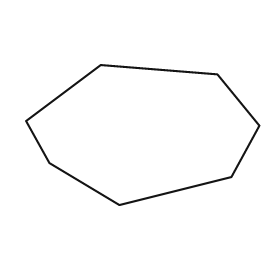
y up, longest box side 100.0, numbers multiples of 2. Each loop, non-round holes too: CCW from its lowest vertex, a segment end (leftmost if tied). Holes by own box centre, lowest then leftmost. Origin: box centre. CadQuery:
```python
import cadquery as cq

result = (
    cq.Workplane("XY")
    .moveTo(-10.0, -30.0)
    .lineTo(38.0, -18.0)
    .lineTo(50.0, 4.0)
    .lineTo(32.0, 26.0)
    .lineTo(-18.0, 30.0)
    .lineTo(-50.0, 6.0)
    .lineTo(-40.0, -12.0)
    .close()
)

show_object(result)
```